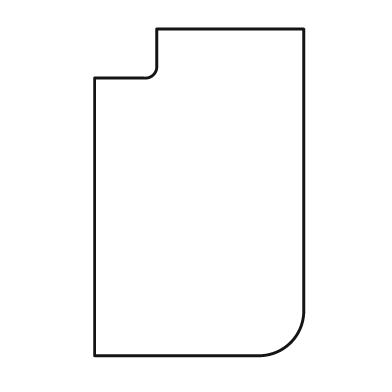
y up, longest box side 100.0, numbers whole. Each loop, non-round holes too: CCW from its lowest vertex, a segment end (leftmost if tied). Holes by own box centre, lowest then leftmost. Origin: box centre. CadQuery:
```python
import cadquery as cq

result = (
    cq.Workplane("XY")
    .moveTo(-32.0, -50.0)
    .lineTo(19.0, -50.0)
    .threePointArc((28.0, -46.0), (32.0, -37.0))
    .lineTo(32.0, 50.0)
    .lineTo(-13.0, 50.0)
    .lineTo(-13.0, 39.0)
    .threePointArc((-14.0, 36.0), (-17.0, 35.0))
    .lineTo(-32.0, 35.0)
    .close()
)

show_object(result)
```